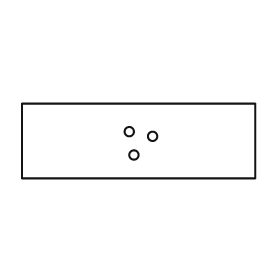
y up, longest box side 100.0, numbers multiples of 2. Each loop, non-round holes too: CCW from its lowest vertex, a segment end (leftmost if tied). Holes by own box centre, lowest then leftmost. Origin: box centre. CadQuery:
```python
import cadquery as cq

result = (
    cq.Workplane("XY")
    .moveTo(-50.0, -16.0)
    .lineTo(50.0, -16.0)
    .lineTo(50.0, 16.0)
    .lineTo(-50.0, 16.0)
    .close()
    .moveTo(-2.0, -6.0)
    .circle(2.0)
    .moveTo(6.0, 2.0)
    .circle(2.0)
    .moveTo(-4.0, 4.0)
    .circle(2.0)
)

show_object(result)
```